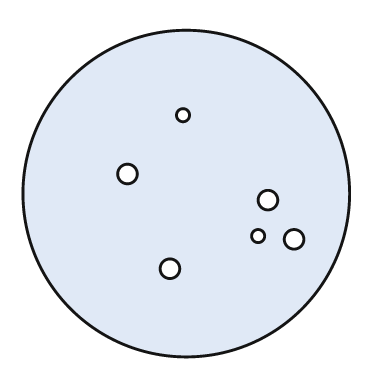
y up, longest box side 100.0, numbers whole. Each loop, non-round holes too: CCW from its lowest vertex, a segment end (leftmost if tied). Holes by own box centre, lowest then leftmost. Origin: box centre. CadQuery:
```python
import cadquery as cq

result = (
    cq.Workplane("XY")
    .moveTo(0.0, 0.0)
    .circle(50.0)
    .moveTo(-5.0, -23.0)
    .circle(3.0)
    .moveTo(33.0, -14.0)
    .circle(3.0)
    .moveTo(22.0, -13.0)
    .circle(2.0)
    .moveTo(25.0, -2.0)
    .circle(3.0)
    .moveTo(-18.0, 6.0)
    .circle(3.0)
    .moveTo(-1.0, 24.0)
    .circle(2.0)
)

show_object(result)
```